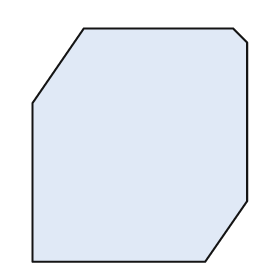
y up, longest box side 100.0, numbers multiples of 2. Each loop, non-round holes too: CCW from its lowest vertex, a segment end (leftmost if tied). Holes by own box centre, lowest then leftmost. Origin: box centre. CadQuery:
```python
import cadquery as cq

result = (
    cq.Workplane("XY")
    .moveTo(-46.0, -50.0)
    .lineTo(28.0, -50.0)
    .lineTo(46.0, -24.0)
    .lineTo(46.0, 44.0)
    .lineTo(40.0, 50.0)
    .lineTo(-24.0, 50.0)
    .lineTo(-46.0, 18.0)
    .close()
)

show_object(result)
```